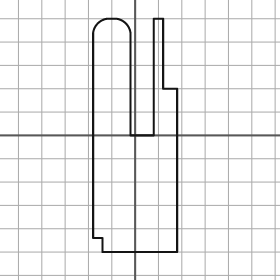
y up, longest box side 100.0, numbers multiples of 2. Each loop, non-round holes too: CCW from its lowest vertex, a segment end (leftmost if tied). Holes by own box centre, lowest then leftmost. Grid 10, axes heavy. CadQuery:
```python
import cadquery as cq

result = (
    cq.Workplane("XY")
    .moveTo(-14.0, -50.0)
    .lineTo(18.0, -50.0)
    .lineTo(18.0, 20.0)
    .lineTo(12.0, 20.0)
    .lineTo(12.0, 50.0)
    .lineTo(8.0, 50.0)
    .lineTo(8.0, 0.0)
    .lineTo(-2.0, 0.0)
    .lineTo(-2.0, 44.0)
    .threePointArc((-4.0, 48.0), (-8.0, 50.0))
    .lineTo(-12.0, 50.0)
    .threePointArc((-16.0, 48.0), (-18.0, 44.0))
    .lineTo(-18.0, -44.0)
    .lineTo(-14.0, -44.0)
    .close()
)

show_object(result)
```